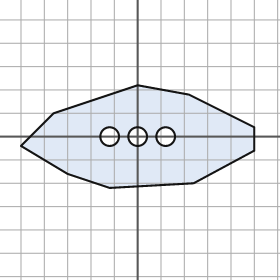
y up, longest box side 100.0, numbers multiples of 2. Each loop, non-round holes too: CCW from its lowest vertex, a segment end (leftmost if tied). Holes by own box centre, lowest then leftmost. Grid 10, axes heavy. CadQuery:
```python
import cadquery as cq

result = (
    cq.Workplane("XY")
    .moveTo(-12.0, -22.0)
    .lineTo(24.0, -20.0)
    .lineTo(50.0, -6.0)
    .lineTo(50.0, 4.0)
    .lineTo(22.0, 18.0)
    .lineTo(0.0, 22.0)
    .lineTo(-36.0, 10.0)
    .lineTo(-50.0, -4.0)
    .lineTo(-30.0, -16.0)
    .close()
    .moveTo(-12.0, 0.0)
    .circle(4.0)
    .moveTo(0.0, 0.0)
    .circle(4.0)
    .moveTo(12.0, 0.0)
    .circle(4.0)
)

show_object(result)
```